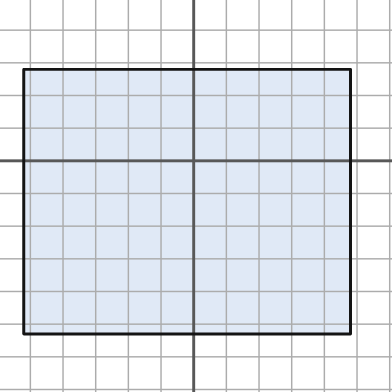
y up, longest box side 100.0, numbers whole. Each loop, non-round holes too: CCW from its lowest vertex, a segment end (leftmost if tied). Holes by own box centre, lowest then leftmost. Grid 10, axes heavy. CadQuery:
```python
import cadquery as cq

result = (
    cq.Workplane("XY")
    .moveTo(-52.0, -53.0)
    .lineTo(48.0, -53.0)
    .lineTo(48.0, 28.0)
    .lineTo(-52.0, 28.0)
    .close()
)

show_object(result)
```